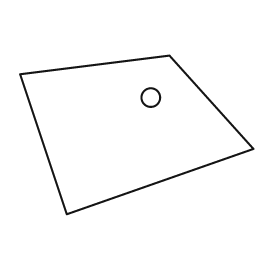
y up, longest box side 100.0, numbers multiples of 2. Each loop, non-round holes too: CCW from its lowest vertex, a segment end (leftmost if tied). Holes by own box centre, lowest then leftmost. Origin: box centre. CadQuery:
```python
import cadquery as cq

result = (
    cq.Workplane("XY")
    .moveTo(-30.0, -34.0)
    .lineTo(50.0, -6.0)
    .lineTo(14.0, 34.0)
    .lineTo(-50.0, 26.0)
    .close()
    .moveTo(6.0, 16.0)
    .circle(4.0)
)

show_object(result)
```